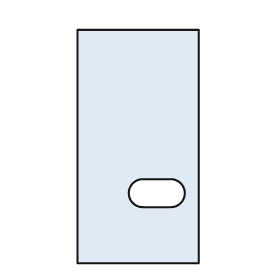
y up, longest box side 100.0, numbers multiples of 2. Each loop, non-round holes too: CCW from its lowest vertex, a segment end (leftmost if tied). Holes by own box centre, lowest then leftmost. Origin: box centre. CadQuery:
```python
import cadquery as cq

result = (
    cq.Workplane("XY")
    .moveTo(-26.0, -50.0)
    .lineTo(26.0, -50.0)
    .lineTo(26.0, 50.0)
    .lineTo(-26.0, 50.0)
    .close()
    .moveTo(2.0, -26.0)
    .lineTo(14.0, -26.0)
    .threePointArc((20.0, -20.0), (14.0, -14.0))
    .lineTo(2.0, -14.0)
    .threePointArc((-4.0, -20.0), (2.0, -26.0))
    .close()
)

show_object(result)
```